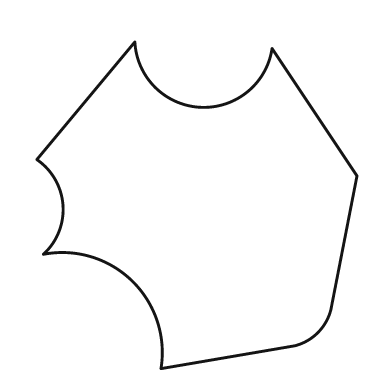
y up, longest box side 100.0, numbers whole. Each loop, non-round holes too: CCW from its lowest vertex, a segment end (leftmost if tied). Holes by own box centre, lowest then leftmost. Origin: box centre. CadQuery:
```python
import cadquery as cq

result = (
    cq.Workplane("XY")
    .moveTo(-11.0, -50.0)
    .lineTo(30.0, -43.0)
    .threePointArc((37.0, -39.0), (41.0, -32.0))
    .lineTo(49.0, 9.0)
    .lineTo(23.0, 48.0)
    .threePointArc((1.0, 30.0), (-19.0, 50.0))
    .lineTo(-49.0, 14.0)
    .threePointArc((-41.0, 0.0), (-47.0, -15.0))
    .threePointArc((-20.0, -23.0), (-11.0, -50.0))
    .close()
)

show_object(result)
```